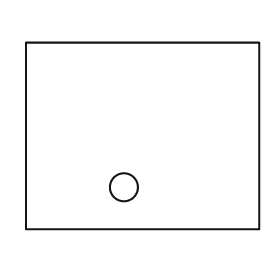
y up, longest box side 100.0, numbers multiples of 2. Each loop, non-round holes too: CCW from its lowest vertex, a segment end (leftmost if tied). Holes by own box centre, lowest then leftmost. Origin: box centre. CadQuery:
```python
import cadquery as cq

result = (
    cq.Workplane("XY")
    .moveTo(-50.0, -40.0)
    .lineTo(50.0, -40.0)
    .lineTo(50.0, 40.0)
    .lineTo(-50.0, 40.0)
    .close()
    .moveTo(-8.0, -22.0)
    .circle(6.0)
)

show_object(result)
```